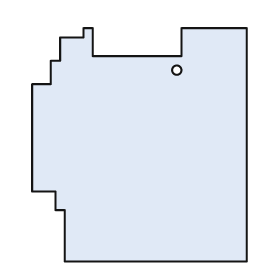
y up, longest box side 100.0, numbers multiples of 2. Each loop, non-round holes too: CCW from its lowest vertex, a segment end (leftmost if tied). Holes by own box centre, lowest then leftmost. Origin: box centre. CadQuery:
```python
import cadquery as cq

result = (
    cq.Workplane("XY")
    .moveTo(-32.0, -50.0)
    .lineTo(46.0, -50.0)
    .lineTo(46.0, 50.0)
    .lineTo(18.0, 50.0)
    .lineTo(18.0, 38.0)
    .lineTo(-20.0, 38.0)
    .lineTo(-20.0, 50.0)
    .lineTo(-24.0, 50.0)
    .lineTo(-24.0, 46.0)
    .lineTo(-34.0, 46.0)
    .lineTo(-34.0, 36.0)
    .lineTo(-38.0, 36.0)
    .lineTo(-38.0, 26.0)
    .lineTo(-46.0, 26.0)
    .lineTo(-46.0, -20.0)
    .lineTo(-36.0, -20.0)
    .lineTo(-36.0, -28.0)
    .lineTo(-32.0, -28.0)
    .close()
    .moveTo(16.0, 32.0)
    .circle(2.0)
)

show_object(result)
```